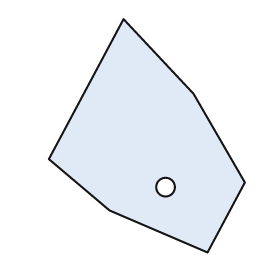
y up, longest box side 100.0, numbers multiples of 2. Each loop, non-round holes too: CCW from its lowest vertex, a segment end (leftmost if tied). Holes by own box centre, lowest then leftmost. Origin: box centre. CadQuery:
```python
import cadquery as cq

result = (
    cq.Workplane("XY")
    .moveTo(26.0, -50.0)
    .lineTo(42.0, -20.0)
    .lineTo(20.0, 18.0)
    .lineTo(-10.0, 50.0)
    .lineTo(-42.0, -10.0)
    .lineTo(-16.0, -32.0)
    .close()
    .moveTo(8.0, -22.0)
    .circle(4.0)
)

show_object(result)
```